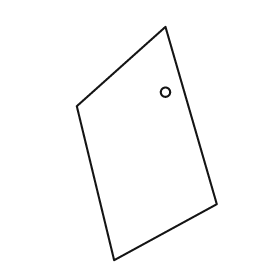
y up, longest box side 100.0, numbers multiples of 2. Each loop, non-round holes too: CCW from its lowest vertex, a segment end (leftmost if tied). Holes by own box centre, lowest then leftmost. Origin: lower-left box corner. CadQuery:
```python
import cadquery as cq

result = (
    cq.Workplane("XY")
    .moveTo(16.0, 0.0)
    .lineTo(60.0, 24.0)
    .lineTo(38.0, 100.0)
    .lineTo(0.0, 66.0)
    .close()
    .moveTo(38.0, 72.0)
    .circle(2.0)
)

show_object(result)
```